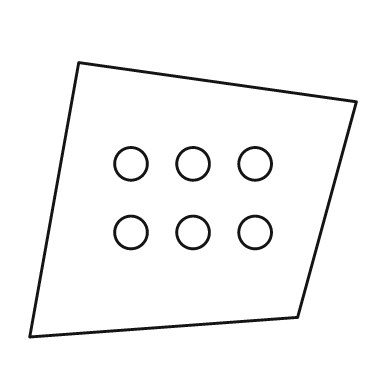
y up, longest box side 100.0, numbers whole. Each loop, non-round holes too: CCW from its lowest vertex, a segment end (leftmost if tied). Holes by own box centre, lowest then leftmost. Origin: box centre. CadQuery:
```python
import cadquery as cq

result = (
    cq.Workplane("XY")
    .moveTo(-50.0, -42.0)
    .lineTo(32.0, -36.0)
    .lineTo(50.0, 30.0)
    .lineTo(-35.0, 42.0)
    .close()
    .moveTo(-19.0, -10.0)
    .circle(5.0)
    .moveTo(0.0, -10.0)
    .circle(5.0)
    .moveTo(19.0, -10.0)
    .circle(5.0)
    .moveTo(-19.0, 11.0)
    .circle(5.0)
    .moveTo(0.0, 11.0)
    .circle(5.0)
    .moveTo(19.0, 11.0)
    .circle(5.0)
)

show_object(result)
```